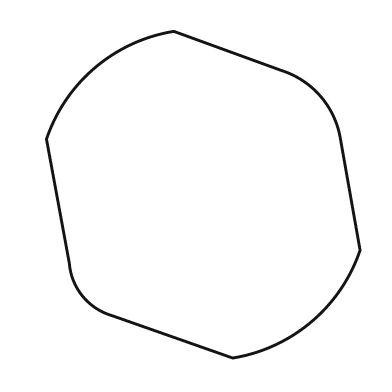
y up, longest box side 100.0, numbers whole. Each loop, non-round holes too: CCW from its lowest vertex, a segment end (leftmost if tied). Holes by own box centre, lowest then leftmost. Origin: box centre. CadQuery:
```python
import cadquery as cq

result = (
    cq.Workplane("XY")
    .moveTo(9.0, -50.0)
    .threePointArc((33.0, -39.0), (48.0, -17.0))
    .lineTo(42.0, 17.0)
    .threePointArc((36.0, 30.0), (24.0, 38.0))
    .lineTo(-9.0, 50.0)
    .threePointArc((-33.0, 39.0), (-48.0, 17.0))
    .lineTo(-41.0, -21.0)
    .threePointArc((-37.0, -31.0), (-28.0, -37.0))
    .close()
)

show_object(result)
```